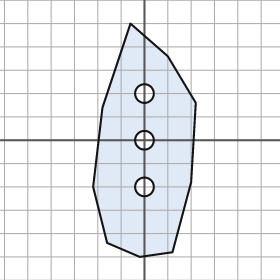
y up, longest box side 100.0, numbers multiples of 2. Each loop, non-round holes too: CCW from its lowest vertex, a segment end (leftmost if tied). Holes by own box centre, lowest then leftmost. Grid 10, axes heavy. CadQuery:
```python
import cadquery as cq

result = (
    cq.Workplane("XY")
    .moveTo(-2.0, -50.0)
    .lineTo(12.0, -48.0)
    .lineTo(20.0, -18.0)
    .lineTo(22.0, 16.0)
    .lineTo(10.0, 36.0)
    .lineTo(-6.0, 50.0)
    .lineTo(-18.0, 14.0)
    .lineTo(-22.0, -20.0)
    .lineTo(-16.0, -44.0)
    .close()
    .moveTo(0.0, -20.0)
    .circle(4.0)
    .moveTo(0.0, 0.0)
    .circle(4.0)
    .moveTo(0.0, 20.0)
    .circle(4.0)
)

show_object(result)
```